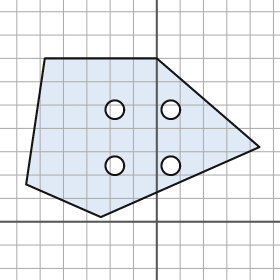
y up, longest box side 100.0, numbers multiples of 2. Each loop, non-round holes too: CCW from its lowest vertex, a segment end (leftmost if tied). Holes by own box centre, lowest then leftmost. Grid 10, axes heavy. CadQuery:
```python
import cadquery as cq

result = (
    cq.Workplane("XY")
    .moveTo(-24.0, 2.0)
    .lineTo(44.0, 32.0)
    .lineTo(0.0, 70.0)
    .lineTo(-48.0, 70.0)
    .lineTo(-56.0, 16.0)
    .close()
    .moveTo(-18.0, 24.0)
    .circle(4.0)
    .moveTo(6.0, 24.0)
    .circle(4.0)
    .moveTo(-18.0, 48.0)
    .circle(4.0)
    .moveTo(6.0, 48.0)
    .circle(4.0)
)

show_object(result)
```